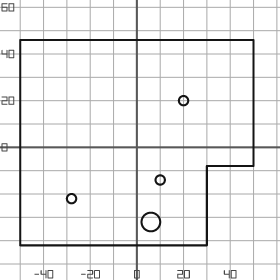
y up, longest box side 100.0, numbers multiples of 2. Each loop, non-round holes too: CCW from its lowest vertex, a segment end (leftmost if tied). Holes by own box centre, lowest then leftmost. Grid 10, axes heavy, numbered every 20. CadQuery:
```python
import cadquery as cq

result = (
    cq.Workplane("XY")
    .moveTo(-50.0, -42.0)
    .lineTo(30.0, -42.0)
    .lineTo(30.0, -8.0)
    .lineTo(50.0, -8.0)
    .lineTo(50.0, 46.0)
    .lineTo(-50.0, 46.0)
    .close()
    .moveTo(6.0, -32.0)
    .circle(4.0)
    .moveTo(-28.0, -22.0)
    .circle(2.0)
    .moveTo(10.0, -14.0)
    .circle(2.0)
    .moveTo(20.0, 20.0)
    .circle(2.0)
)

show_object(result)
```